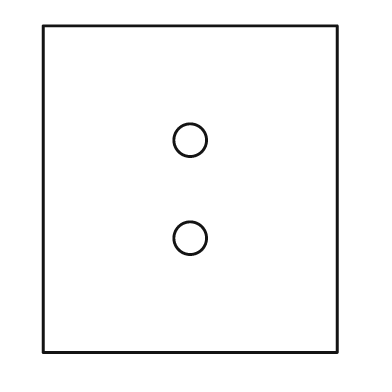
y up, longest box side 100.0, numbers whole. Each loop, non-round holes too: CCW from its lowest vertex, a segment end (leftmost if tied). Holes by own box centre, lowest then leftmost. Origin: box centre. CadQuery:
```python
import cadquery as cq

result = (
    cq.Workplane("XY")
    .moveTo(-45.0, -50.0)
    .lineTo(45.0, -50.0)
    .lineTo(45.0, 50.0)
    .lineTo(-45.0, 50.0)
    .close()
    .moveTo(0.0, -15.0)
    .circle(5.0)
    .moveTo(0.0, 15.0)
    .circle(5.0)
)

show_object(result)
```